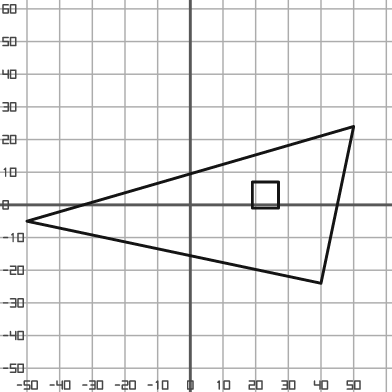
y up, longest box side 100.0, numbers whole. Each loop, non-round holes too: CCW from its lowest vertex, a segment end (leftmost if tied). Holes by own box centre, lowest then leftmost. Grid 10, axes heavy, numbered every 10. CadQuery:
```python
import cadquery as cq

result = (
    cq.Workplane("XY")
    .moveTo(40.0, -24.0)
    .lineTo(50.0, 24.0)
    .lineTo(-50.0, -5.0)
    .close()
    .moveTo(19.0, -1.0)
    .lineTo(27.0, -1.0)
    .lineTo(27.0, 7.0)
    .lineTo(19.0, 7.0)
    .close()
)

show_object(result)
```